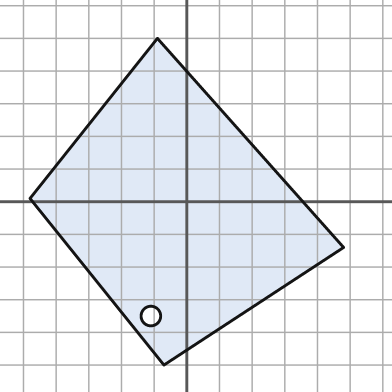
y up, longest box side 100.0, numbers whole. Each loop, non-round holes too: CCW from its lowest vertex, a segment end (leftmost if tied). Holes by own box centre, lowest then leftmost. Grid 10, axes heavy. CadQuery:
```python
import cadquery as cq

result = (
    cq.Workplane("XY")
    .moveTo(-7.0, -50.0)
    .lineTo(48.0, -14.0)
    .lineTo(-9.0, 50.0)
    .lineTo(-48.0, 1.0)
    .close()
    .moveTo(-11.0, -35.0)
    .circle(3.0)
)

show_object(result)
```